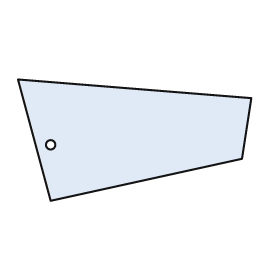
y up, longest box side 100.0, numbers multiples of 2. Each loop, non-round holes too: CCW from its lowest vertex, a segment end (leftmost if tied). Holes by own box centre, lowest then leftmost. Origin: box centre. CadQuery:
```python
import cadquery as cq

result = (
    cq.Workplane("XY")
    .moveTo(-36.0, -26.0)
    .lineTo(46.0, -8.0)
    .lineTo(50.0, 18.0)
    .lineTo(-50.0, 26.0)
    .close()
    .moveTo(-36.0, -2.0)
    .circle(2.0)
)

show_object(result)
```